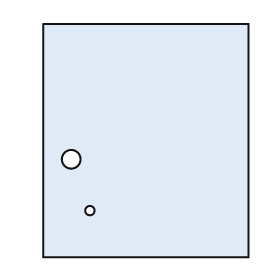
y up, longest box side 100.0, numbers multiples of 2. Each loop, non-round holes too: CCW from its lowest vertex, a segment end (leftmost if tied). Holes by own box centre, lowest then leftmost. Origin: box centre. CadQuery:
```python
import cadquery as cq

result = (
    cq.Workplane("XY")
    .moveTo(-44.0, -50.0)
    .lineTo(44.0, -50.0)
    .lineTo(44.0, 50.0)
    .lineTo(-44.0, 50.0)
    .close()
    .moveTo(-24.0, -30.0)
    .circle(2.0)
    .moveTo(-32.0, -8.0)
    .circle(4.0)
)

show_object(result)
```